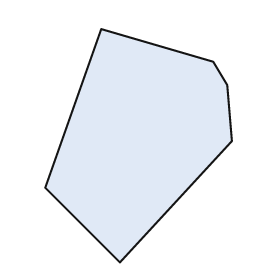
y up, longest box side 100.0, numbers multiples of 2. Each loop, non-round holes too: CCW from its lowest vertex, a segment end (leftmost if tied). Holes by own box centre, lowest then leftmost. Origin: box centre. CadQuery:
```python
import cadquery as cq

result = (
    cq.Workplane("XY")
    .moveTo(-8.0, -50.0)
    .lineTo(40.0, 2.0)
    .lineTo(38.0, 26.0)
    .lineTo(32.0, 36.0)
    .lineTo(-16.0, 50.0)
    .lineTo(-40.0, -18.0)
    .close()
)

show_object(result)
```